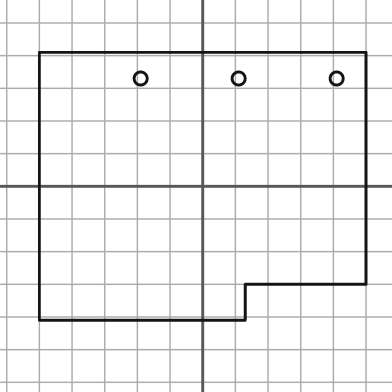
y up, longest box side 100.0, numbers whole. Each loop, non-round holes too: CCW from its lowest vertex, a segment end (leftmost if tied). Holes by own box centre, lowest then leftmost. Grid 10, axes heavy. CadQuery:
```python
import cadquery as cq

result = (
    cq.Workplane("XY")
    .moveTo(-50.0, -41.0)
    .lineTo(13.0, -41.0)
    .lineTo(13.0, -30.0)
    .lineTo(50.0, -30.0)
    .lineTo(50.0, 41.0)
    .lineTo(-50.0, 41.0)
    .close()
    .moveTo(-19.0, 33.0)
    .circle(2.0)
    .moveTo(11.0, 33.0)
    .circle(2.0)
    .moveTo(41.0, 33.0)
    .circle(2.0)
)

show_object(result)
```